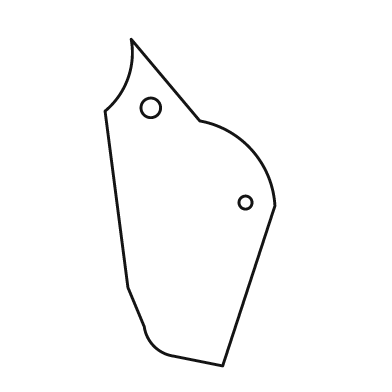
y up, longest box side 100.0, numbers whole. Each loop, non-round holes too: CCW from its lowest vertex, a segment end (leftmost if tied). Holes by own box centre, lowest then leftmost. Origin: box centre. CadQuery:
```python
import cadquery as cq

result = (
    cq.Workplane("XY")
    .moveTo(10.0, -50.0)
    .lineTo(26.0, -1.0)
    .threePointArc((19.0, 16.0), (3.0, 25.0))
    .lineTo(-18.0, 50.0)
    .threePointArc((-19.0, 38.0), (-26.0, 28.0))
    .lineTo(-19.0, -26.0)
    .lineTo(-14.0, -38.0)
    .threePointArc((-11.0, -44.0), (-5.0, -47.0))
    .close()
    .moveTo(17.0, 0.0)
    .circle(2.0)
    .moveTo(-12.0, 29.0)
    .circle(3.0)
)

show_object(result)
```